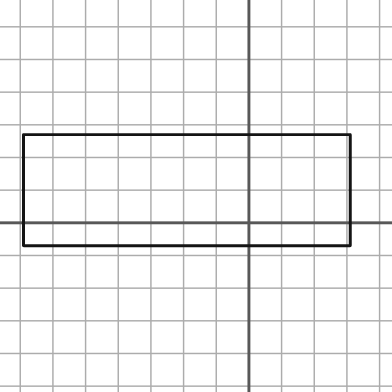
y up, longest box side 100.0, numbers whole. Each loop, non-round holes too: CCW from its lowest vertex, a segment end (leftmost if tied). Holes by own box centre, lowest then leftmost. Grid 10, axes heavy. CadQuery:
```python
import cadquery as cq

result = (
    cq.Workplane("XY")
    .moveTo(-69.0, -7.0)
    .lineTo(31.0, -7.0)
    .lineTo(31.0, 27.0)
    .lineTo(-69.0, 27.0)
    .close()
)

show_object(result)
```